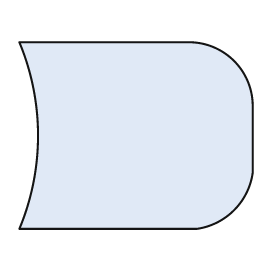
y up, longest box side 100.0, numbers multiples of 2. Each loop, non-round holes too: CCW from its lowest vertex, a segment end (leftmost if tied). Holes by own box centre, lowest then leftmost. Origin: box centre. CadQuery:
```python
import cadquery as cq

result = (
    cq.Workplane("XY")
    .moveTo(-50.0, -40.0)
    .lineTo(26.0, -40.0)
    .threePointArc((42.0, -32.0), (50.0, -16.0))
    .lineTo(50.0, 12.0)
    .threePointArc((42.0, 32.0), (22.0, 40.0))
    .lineTo(-50.0, 40.0)
    .threePointArc((-42.0, 0.0), (-50.0, -40.0))
    .close()
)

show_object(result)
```